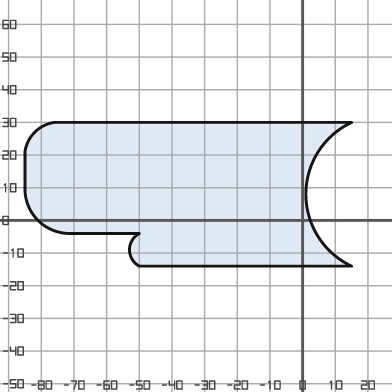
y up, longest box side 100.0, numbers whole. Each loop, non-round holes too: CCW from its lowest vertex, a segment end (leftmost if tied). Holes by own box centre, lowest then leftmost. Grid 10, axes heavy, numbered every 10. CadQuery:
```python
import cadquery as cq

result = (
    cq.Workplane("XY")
    .moveTo(-50.0, -14.0)
    .lineTo(15.0, -14.0)
    .threePointArc((1.0, 8.0), (15.0, 30.0))
    .lineTo(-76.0, 30.0)
    .threePointArc((-82.0, 27.0), (-85.0, 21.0))
    .lineTo(-85.0, 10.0)
    .threePointArc((-81.0, 0.0), (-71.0, -4.0))
    .lineTo(-50.0, -4.0)
    .threePointArc((-53.0, -9.0), (-50.0, -14.0))
    .close()
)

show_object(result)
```